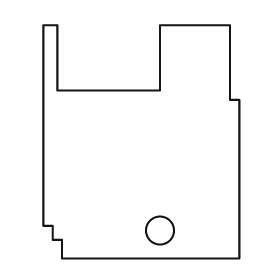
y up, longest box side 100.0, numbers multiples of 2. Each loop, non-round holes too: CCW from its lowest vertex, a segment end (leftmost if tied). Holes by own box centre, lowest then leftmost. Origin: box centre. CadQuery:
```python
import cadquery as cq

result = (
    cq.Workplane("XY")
    .moveTo(-34.0, -50.0)
    .lineTo(42.0, -50.0)
    .lineTo(42.0, 18.0)
    .lineTo(38.0, 18.0)
    .lineTo(38.0, 50.0)
    .lineTo(8.0, 50.0)
    .lineTo(8.0, 22.0)
    .lineTo(-36.0, 22.0)
    .lineTo(-36.0, 50.0)
    .lineTo(-42.0, 50.0)
    .lineTo(-42.0, -36.0)
    .lineTo(-38.0, -36.0)
    .lineTo(-38.0, -42.0)
    .lineTo(-34.0, -42.0)
    .close()
    .moveTo(8.0, -38.0)
    .circle(6.0)
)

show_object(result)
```